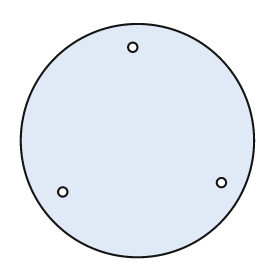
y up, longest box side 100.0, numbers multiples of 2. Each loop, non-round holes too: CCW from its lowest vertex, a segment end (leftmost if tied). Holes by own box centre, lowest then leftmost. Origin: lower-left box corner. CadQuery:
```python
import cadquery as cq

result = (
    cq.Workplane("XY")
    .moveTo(50.0, 50.0)
    .circle(50.0)
    .moveTo(18.0, 28.0)
    .circle(2.0)
    .moveTo(86.0, 32.0)
    .circle(2.0)
    .moveTo(48.0, 90.0)
    .circle(2.0)
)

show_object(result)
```